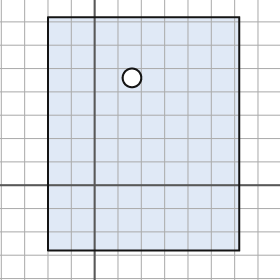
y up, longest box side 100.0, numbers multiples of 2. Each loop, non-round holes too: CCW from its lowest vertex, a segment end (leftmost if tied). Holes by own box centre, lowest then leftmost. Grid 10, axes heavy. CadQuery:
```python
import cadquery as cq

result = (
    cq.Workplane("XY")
    .moveTo(-20.0, -28.0)
    .lineTo(62.0, -28.0)
    .lineTo(62.0, 72.0)
    .lineTo(-20.0, 72.0)
    .close()
    .moveTo(16.0, 46.0)
    .circle(4.0)
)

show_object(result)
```